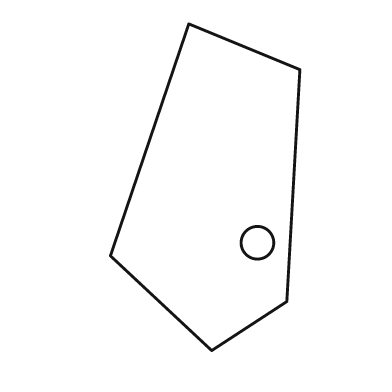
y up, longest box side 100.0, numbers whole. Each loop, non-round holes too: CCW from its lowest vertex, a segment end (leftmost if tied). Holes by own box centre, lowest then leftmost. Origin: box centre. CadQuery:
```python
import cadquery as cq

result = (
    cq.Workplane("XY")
    .moveTo(2.0, -50.0)
    .lineTo(25.0, -35.0)
    .lineTo(29.0, 36.0)
    .lineTo(-5.0, 50.0)
    .lineTo(-29.0, -21.0)
    .close()
    .moveTo(16.0, -17.0)
    .circle(5.0)
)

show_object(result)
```